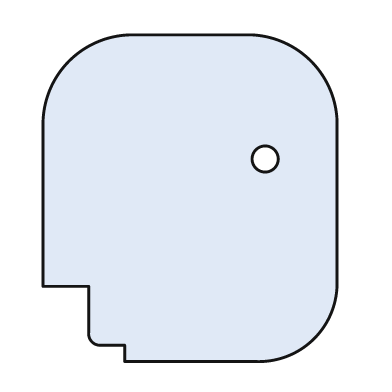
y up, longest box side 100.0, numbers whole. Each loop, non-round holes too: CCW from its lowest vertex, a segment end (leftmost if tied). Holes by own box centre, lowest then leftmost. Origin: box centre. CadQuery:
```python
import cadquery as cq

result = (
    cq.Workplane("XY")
    .moveTo(-20.0, -50.0)
    .lineTo(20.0, -50.0)
    .threePointArc((38.0, -43.0), (45.0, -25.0))
    .lineTo(45.0, 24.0)
    .threePointArc((37.0, 42.0), (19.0, 50.0))
    .lineTo(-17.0, 50.0)
    .threePointArc((-37.0, 42.0), (-45.0, 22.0))
    .lineTo(-45.0, -27.0)
    .lineTo(-31.0, -27.0)
    .lineTo(-31.0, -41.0)
    .threePointArc((-30.0, -44.0), (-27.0, -45.0))
    .lineTo(-20.0, -45.0)
    .close()
    .moveTo(23.0, 12.0)
    .circle(4.0)
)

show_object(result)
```